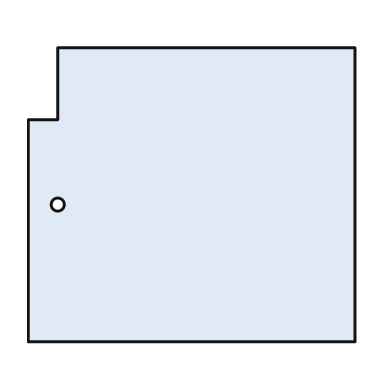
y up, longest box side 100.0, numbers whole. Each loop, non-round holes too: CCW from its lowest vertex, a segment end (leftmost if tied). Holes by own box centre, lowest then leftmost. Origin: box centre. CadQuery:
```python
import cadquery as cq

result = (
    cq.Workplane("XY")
    .moveTo(-50.0, -45.0)
    .lineTo(50.0, -45.0)
    .lineTo(50.0, 45.0)
    .lineTo(-41.0, 45.0)
    .lineTo(-41.0, 23.0)
    .lineTo(-50.0, 23.0)
    .close()
    .moveTo(-41.0, -3.0)
    .circle(2.0)
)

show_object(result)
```